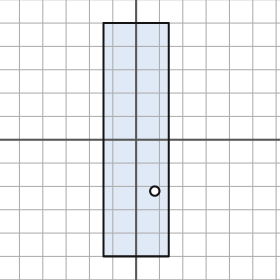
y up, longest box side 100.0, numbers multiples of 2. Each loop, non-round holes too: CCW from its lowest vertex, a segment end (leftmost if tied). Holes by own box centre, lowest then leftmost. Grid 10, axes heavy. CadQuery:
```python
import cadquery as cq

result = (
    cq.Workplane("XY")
    .moveTo(-14.0, -50.0)
    .lineTo(14.0, -50.0)
    .lineTo(14.0, 50.0)
    .lineTo(-14.0, 50.0)
    .close()
    .moveTo(8.0, -22.0)
    .circle(2.0)
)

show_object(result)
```